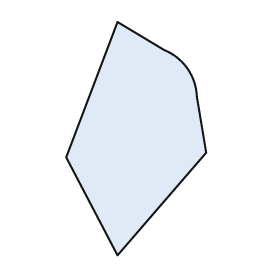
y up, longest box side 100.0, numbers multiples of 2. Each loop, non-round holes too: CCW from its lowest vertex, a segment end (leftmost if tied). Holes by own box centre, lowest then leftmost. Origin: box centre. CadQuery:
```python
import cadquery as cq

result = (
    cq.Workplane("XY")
    .moveTo(-8.0, -50.0)
    .lineTo(30.0, -6.0)
    .lineTo(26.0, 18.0)
    .threePointArc((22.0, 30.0), (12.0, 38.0))
    .lineTo(-8.0, 50.0)
    .lineTo(-30.0, -8.0)
    .close()
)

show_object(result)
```